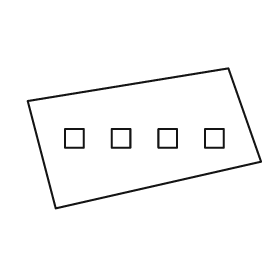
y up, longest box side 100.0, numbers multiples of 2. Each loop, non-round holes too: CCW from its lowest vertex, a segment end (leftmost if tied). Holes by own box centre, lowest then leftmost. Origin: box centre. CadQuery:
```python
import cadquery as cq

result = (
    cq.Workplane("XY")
    .moveTo(-38.0, -30.0)
    .lineTo(50.0, -10.0)
    .lineTo(36.0, 30.0)
    .lineTo(-50.0, 16.0)
    .close()
    .moveTo(-34.0, -4.0)
    .lineTo(-26.0, -4.0)
    .lineTo(-26.0, 4.0)
    .lineTo(-34.0, 4.0)
    .close()
    .moveTo(-14.0, -4.0)
    .lineTo(-6.0, -4.0)
    .lineTo(-6.0, 4.0)
    .lineTo(-14.0, 4.0)
    .close()
    .moveTo(6.0, -4.0)
    .lineTo(14.0, -4.0)
    .lineTo(14.0, 4.0)
    .lineTo(6.0, 4.0)
    .close()
    .moveTo(26.0, -4.0)
    .lineTo(34.0, -4.0)
    .lineTo(34.0, 4.0)
    .lineTo(26.0, 4.0)
    .close()
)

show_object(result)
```